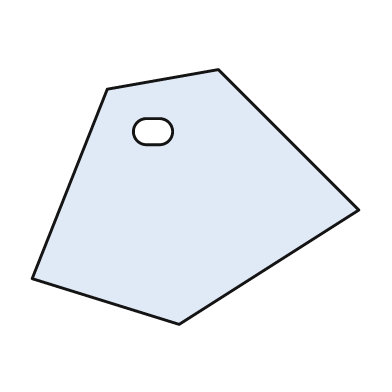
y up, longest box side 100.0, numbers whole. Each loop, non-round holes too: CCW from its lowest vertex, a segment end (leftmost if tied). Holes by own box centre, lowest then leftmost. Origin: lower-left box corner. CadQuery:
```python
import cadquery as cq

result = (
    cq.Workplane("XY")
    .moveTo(45.0, 0.0)
    .lineTo(100.0, 35.0)
    .lineTo(57.0, 78.0)
    .lineTo(23.0, 72.0)
    .lineTo(0.0, 14.0)
    .close()
    .moveTo(35.0, 55.0)
    .lineTo(39.0, 55.0)
    .threePointArc((43.0, 59.0), (39.0, 63.0))
    .lineTo(35.0, 63.0)
    .threePointArc((31.0, 59.0), (35.0, 55.0))
    .close()
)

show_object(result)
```